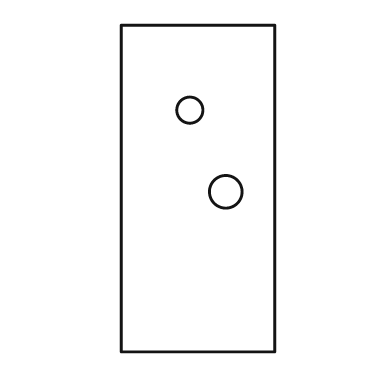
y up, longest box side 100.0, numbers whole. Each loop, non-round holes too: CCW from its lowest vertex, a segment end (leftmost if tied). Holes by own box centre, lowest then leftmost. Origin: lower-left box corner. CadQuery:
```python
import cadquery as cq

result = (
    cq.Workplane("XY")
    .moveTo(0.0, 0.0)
    .lineTo(47.0, 0.0)
    .lineTo(47.0, 100.0)
    .lineTo(0.0, 100.0)
    .close()
    .moveTo(32.0, 49.0)
    .circle(5.0)
    .moveTo(21.0, 74.0)
    .circle(4.0)
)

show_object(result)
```